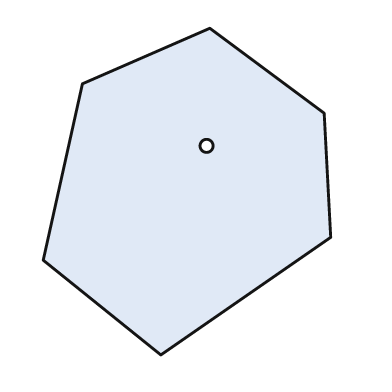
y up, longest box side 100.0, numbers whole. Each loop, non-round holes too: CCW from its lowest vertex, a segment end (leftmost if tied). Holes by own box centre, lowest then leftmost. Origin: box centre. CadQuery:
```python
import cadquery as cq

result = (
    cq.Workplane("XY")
    .moveTo(-8.0, -50.0)
    .lineTo(44.0, -14.0)
    .lineTo(42.0, 24.0)
    .lineTo(7.0, 50.0)
    .lineTo(-32.0, 33.0)
    .lineTo(-44.0, -21.0)
    .close()
    .moveTo(6.0, 14.0)
    .circle(2.0)
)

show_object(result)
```